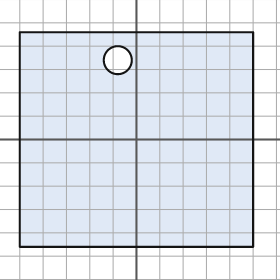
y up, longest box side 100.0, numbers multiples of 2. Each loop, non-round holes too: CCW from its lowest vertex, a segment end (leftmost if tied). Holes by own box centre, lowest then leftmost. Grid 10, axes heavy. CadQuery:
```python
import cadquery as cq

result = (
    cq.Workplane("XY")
    .moveTo(-50.0, -46.0)
    .lineTo(50.0, -46.0)
    .lineTo(50.0, 46.0)
    .lineTo(-50.0, 46.0)
    .close()
    .moveTo(-8.0, 34.0)
    .circle(6.0)
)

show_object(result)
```